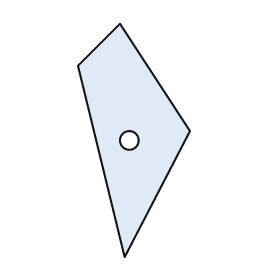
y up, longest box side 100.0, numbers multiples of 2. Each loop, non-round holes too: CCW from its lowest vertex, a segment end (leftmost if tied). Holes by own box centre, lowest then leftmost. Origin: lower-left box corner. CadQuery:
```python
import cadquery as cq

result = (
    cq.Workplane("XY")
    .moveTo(20.0, 0.0)
    .lineTo(48.0, 54.0)
    .lineTo(18.0, 100.0)
    .lineTo(0.0, 82.0)
    .close()
    .moveTo(22.0, 50.0)
    .circle(4.0)
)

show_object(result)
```